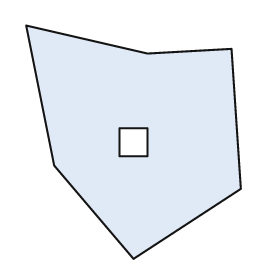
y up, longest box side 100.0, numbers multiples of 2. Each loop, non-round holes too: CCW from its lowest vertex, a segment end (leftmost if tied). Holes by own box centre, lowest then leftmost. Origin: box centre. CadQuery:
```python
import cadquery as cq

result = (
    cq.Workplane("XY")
    .moveTo(0.0, -50.0)
    .lineTo(46.0, -20.0)
    .lineTo(42.0, 40.0)
    .lineTo(6.0, 38.0)
    .lineTo(-46.0, 50.0)
    .lineTo(-34.0, -10.0)
    .close()
    .moveTo(-6.0, -6.0)
    .lineTo(6.0, -6.0)
    .lineTo(6.0, 6.0)
    .lineTo(-6.0, 6.0)
    .close()
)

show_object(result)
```